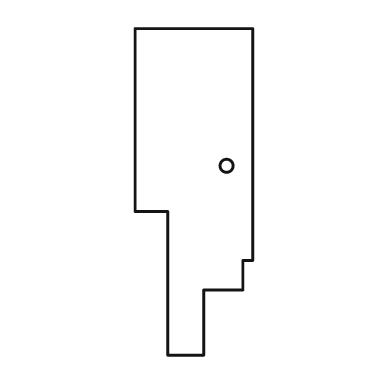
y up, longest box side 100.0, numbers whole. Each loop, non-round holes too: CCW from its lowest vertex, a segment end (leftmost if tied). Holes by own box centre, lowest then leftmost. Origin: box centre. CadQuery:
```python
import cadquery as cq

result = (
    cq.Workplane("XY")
    .moveTo(-8.0, -50.0)
    .lineTo(3.0, -50.0)
    .lineTo(3.0, -30.0)
    .lineTo(15.0, -30.0)
    .lineTo(15.0, -21.0)
    .lineTo(18.0, -21.0)
    .lineTo(18.0, 50.0)
    .lineTo(-18.0, 50.0)
    .lineTo(-18.0, -6.0)
    .lineTo(-8.0, -6.0)
    .close()
    .moveTo(10.0, 8.0)
    .circle(2.0)
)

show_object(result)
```